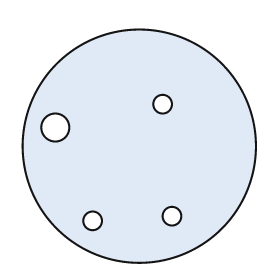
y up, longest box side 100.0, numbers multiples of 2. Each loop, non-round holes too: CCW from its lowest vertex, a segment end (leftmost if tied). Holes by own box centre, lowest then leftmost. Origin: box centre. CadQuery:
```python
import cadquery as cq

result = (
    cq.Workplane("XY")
    .moveTo(0.0, 0.0)
    .circle(50.0)
    .moveTo(-20.0, -32.0)
    .circle(4.0)
    .moveTo(14.0, -30.0)
    .circle(4.0)
    .moveTo(-36.0, 8.0)
    .circle(6.0)
    .moveTo(10.0, 18.0)
    .circle(4.0)
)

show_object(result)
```